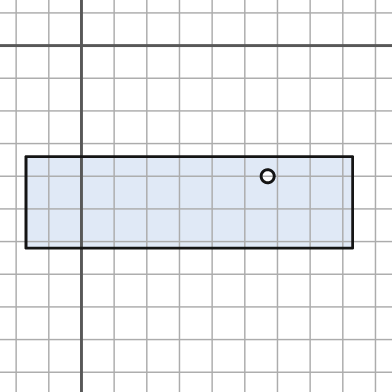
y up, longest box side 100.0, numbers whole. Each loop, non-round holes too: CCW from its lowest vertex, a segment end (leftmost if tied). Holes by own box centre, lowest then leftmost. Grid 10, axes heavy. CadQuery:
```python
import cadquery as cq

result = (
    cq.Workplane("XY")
    .moveTo(-17.0, -62.0)
    .lineTo(83.0, -62.0)
    .lineTo(83.0, -34.0)
    .lineTo(-17.0, -34.0)
    .close()
    .moveTo(57.0, -40.0)
    .circle(2.0)
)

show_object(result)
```